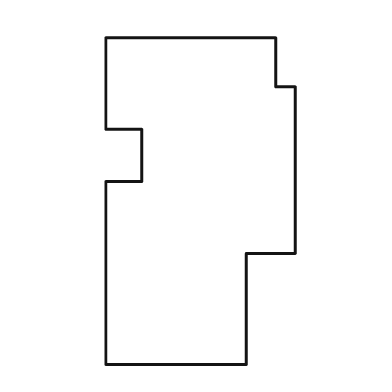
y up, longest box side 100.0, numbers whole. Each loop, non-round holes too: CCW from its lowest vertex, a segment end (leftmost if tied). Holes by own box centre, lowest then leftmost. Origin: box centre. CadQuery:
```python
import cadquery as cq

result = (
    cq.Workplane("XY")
    .moveTo(-29.0, -50.0)
    .lineTo(14.0, -50.0)
    .lineTo(14.0, -16.0)
    .lineTo(29.0, -16.0)
    .lineTo(29.0, 35.0)
    .lineTo(23.0, 35.0)
    .lineTo(23.0, 50.0)
    .lineTo(-29.0, 50.0)
    .lineTo(-29.0, 22.0)
    .lineTo(-18.0, 22.0)
    .lineTo(-18.0, 6.0)
    .lineTo(-29.0, 6.0)
    .close()
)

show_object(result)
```